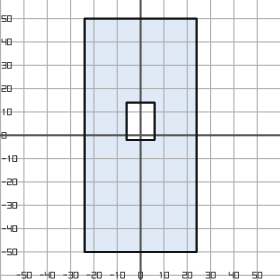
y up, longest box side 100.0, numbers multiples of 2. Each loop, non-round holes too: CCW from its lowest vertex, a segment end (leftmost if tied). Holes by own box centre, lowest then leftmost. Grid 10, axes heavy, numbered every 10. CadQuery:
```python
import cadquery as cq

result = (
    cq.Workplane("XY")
    .moveTo(-24.0, -50.0)
    .lineTo(24.0, -50.0)
    .lineTo(24.0, 50.0)
    .lineTo(-24.0, 50.0)
    .close()
    .moveTo(-6.0, -2.0)
    .lineTo(6.0, -2.0)
    .lineTo(6.0, 14.0)
    .lineTo(-6.0, 14.0)
    .close()
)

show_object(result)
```